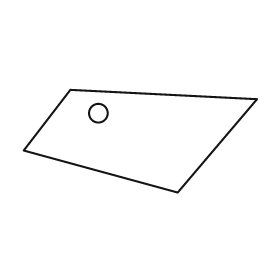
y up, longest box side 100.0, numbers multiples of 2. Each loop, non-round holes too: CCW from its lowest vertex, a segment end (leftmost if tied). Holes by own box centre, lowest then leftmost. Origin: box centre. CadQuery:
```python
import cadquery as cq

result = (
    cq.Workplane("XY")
    .moveTo(16.0, -22.0)
    .lineTo(50.0, 18.0)
    .lineTo(-30.0, 22.0)
    .lineTo(-50.0, -4.0)
    .close()
    .moveTo(-18.0, 12.0)
    .circle(4.0)
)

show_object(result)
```